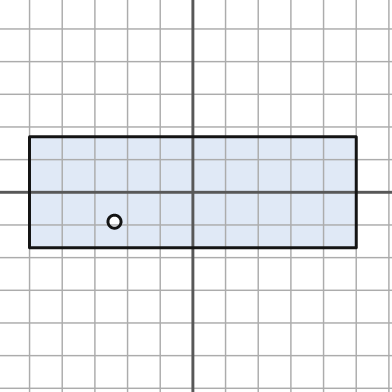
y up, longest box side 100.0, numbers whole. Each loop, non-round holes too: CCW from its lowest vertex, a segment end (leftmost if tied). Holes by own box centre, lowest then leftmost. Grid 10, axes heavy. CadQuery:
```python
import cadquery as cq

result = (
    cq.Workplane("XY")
    .moveTo(-50.0, -17.0)
    .lineTo(50.0, -17.0)
    .lineTo(50.0, 17.0)
    .lineTo(-50.0, 17.0)
    .close()
    .moveTo(-24.0, -9.0)
    .circle(2.0)
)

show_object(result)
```